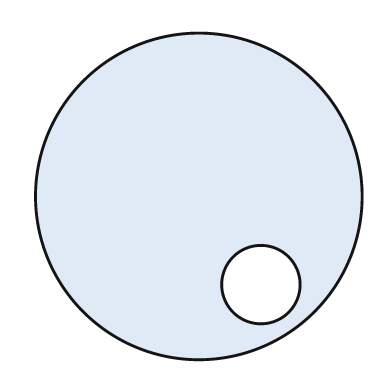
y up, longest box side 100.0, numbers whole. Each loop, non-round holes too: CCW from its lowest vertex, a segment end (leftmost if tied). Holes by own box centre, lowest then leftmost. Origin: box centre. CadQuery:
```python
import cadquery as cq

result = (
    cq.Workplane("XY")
    .moveTo(0.0, 0.0)
    .circle(50.0)
    .moveTo(19.0, -27.0)
    .circle(12.0)
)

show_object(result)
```